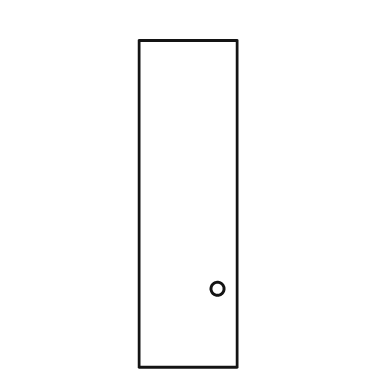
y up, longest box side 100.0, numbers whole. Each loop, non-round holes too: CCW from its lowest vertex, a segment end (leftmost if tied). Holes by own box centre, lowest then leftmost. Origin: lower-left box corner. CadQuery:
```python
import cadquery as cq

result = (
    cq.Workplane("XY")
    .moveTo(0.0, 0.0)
    .lineTo(30.0, 0.0)
    .lineTo(30.0, 100.0)
    .lineTo(0.0, 100.0)
    .close()
    .moveTo(24.0, 24.0)
    .circle(2.0)
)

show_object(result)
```